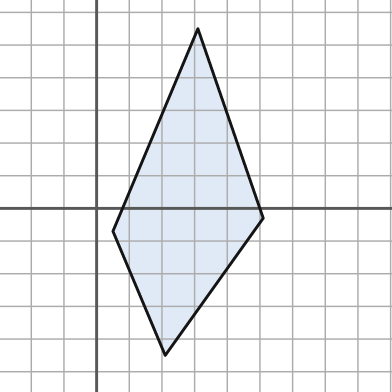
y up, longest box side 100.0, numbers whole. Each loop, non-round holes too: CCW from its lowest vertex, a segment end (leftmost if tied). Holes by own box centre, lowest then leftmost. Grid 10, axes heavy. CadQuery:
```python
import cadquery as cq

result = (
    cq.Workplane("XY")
    .moveTo(21.0, -45.0)
    .lineTo(51.0, -3.0)
    .lineTo(31.0, 55.0)
    .lineTo(5.0, -7.0)
    .close()
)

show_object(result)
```